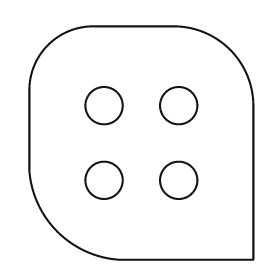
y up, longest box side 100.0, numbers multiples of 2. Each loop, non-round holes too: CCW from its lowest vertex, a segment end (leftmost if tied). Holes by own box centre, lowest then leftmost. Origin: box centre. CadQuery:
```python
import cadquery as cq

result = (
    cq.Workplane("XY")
    .moveTo(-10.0, -50.0)
    .lineTo(48.0, -50.0)
    .lineTo(48.0, 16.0)
    .threePointArc((38.0, 40.0), (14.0, 50.0))
    .lineTo(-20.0, 50.0)
    .threePointArc((-40.0, 42.0), (-48.0, 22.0))
    .lineTo(-48.0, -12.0)
    .threePointArc((-36.0, -38.0), (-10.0, -50.0))
    .close()
    .moveTo(-16.0, -16.0)
    .circle(8.0)
    .moveTo(16.0, -16.0)
    .circle(8.0)
    .moveTo(-16.0, 16.0)
    .circle(8.0)
    .moveTo(16.0, 16.0)
    .circle(8.0)
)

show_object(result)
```